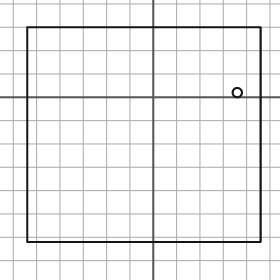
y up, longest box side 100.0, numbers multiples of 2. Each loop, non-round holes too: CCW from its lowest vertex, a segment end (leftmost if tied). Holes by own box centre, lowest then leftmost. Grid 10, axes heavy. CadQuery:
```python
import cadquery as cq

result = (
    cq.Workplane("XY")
    .moveTo(-54.0, -62.0)
    .lineTo(46.0, -62.0)
    .lineTo(46.0, 30.0)
    .lineTo(-54.0, 30.0)
    .close()
    .moveTo(36.0, 2.0)
    .circle(2.0)
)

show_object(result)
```